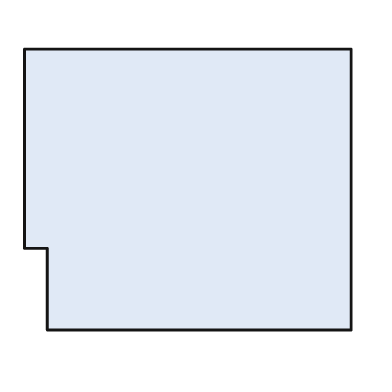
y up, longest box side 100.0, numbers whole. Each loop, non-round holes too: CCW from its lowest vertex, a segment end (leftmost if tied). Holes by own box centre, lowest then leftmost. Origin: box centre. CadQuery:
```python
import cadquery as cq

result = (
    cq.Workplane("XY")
    .moveTo(-43.0, -43.0)
    .lineTo(50.0, -43.0)
    .lineTo(50.0, 43.0)
    .lineTo(-50.0, 43.0)
    .lineTo(-50.0, -18.0)
    .lineTo(-43.0, -18.0)
    .close()
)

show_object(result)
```